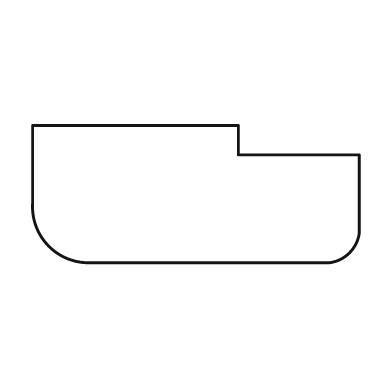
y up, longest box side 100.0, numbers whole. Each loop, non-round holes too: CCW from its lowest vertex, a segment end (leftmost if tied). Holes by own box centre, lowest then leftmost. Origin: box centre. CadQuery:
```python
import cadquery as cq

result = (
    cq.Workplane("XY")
    .moveTo(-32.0, -21.0)
    .lineTo(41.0, -21.0)
    .threePointArc((47.0, -18.0), (50.0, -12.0))
    .lineTo(50.0, 12.0)
    .lineTo(13.0, 12.0)
    .lineTo(13.0, 21.0)
    .lineTo(-50.0, 21.0)
    .lineTo(-50.0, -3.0)
    .threePointArc((-45.0, -16.0), (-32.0, -21.0))
    .close()
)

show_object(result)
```